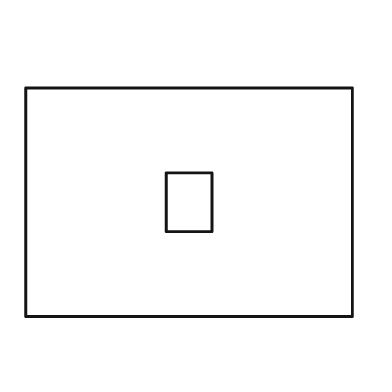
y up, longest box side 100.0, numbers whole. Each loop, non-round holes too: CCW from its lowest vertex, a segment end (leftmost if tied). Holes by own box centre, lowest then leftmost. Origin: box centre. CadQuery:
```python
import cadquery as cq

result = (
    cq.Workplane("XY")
    .moveTo(-50.0, -35.0)
    .lineTo(50.0, -35.0)
    .lineTo(50.0, 35.0)
    .lineTo(-50.0, 35.0)
    .close()
    .moveTo(-7.0, -9.0)
    .lineTo(7.0, -9.0)
    .lineTo(7.0, 9.0)
    .lineTo(-7.0, 9.0)
    .close()
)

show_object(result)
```